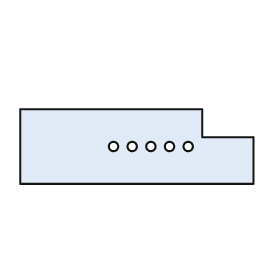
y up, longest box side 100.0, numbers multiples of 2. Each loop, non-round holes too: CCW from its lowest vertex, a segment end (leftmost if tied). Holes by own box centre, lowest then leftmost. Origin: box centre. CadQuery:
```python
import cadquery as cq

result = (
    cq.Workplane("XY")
    .moveTo(-50.0, -16.0)
    .lineTo(50.0, -16.0)
    .lineTo(50.0, 4.0)
    .lineTo(28.0, 4.0)
    .lineTo(28.0, 16.0)
    .lineTo(-50.0, 16.0)
    .close()
    .moveTo(-10.0, 0.0)
    .circle(2.0)
    .moveTo(-2.0, 0.0)
    .circle(2.0)
    .moveTo(6.0, 0.0)
    .circle(2.0)
    .moveTo(14.0, 0.0)
    .circle(2.0)
    .moveTo(22.0, 0.0)
    .circle(2.0)
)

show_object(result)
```